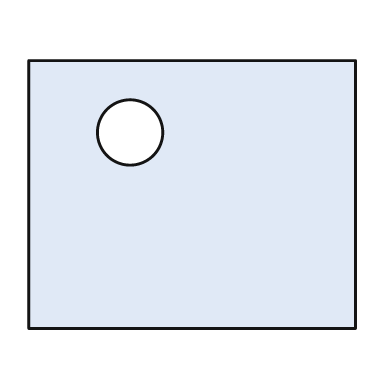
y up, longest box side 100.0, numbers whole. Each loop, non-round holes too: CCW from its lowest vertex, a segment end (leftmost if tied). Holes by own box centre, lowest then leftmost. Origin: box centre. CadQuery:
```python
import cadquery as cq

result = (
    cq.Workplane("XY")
    .moveTo(-50.0, -41.0)
    .lineTo(50.0, -41.0)
    .lineTo(50.0, 41.0)
    .lineTo(-50.0, 41.0)
    .close()
    .moveTo(-19.0, 19.0)
    .circle(10.0)
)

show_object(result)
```